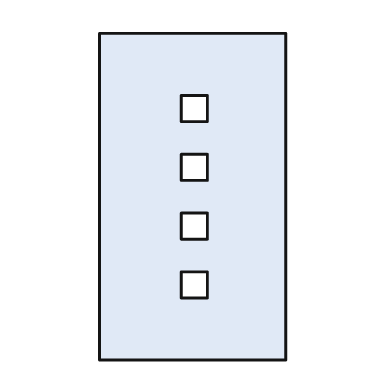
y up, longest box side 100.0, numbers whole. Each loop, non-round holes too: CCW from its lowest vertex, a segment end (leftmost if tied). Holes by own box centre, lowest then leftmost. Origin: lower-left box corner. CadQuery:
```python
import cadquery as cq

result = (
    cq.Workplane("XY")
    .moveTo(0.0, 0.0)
    .lineTo(57.0, 0.0)
    .lineTo(57.0, 100.0)
    .lineTo(0.0, 100.0)
    .close()
    .moveTo(25.0, 19.0)
    .lineTo(33.0, 19.0)
    .lineTo(33.0, 27.0)
    .lineTo(25.0, 27.0)
    .close()
    .moveTo(25.0, 37.0)
    .lineTo(33.0, 37.0)
    .lineTo(33.0, 45.0)
    .lineTo(25.0, 45.0)
    .close()
    .moveTo(25.0, 55.0)
    .lineTo(33.0, 55.0)
    .lineTo(33.0, 63.0)
    .lineTo(25.0, 63.0)
    .close()
    .moveTo(25.0, 73.0)
    .lineTo(33.0, 73.0)
    .lineTo(33.0, 81.0)
    .lineTo(25.0, 81.0)
    .close()
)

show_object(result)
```